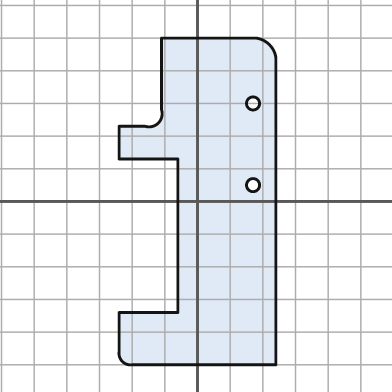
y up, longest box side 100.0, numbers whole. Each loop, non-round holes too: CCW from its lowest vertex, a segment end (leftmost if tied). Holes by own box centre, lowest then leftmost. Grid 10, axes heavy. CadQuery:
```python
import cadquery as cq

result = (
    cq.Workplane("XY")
    .moveTo(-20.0, -50.0)
    .lineTo(24.0, -50.0)
    .lineTo(24.0, 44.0)
    .threePointArc((22.0, 48.0), (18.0, 50.0))
    .lineTo(-11.0, 50.0)
    .lineTo(-11.0, 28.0)
    .threePointArc((-12.0, 24.0), (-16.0, 23.0))
    .lineTo(-24.0, 23.0)
    .lineTo(-24.0, 13.0)
    .lineTo(-6.0, 13.0)
    .lineTo(-6.0, -34.0)
    .lineTo(-24.0, -34.0)
    .lineTo(-24.0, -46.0)
    .threePointArc((-23.0, -49.0), (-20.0, -50.0))
    .close()
    .moveTo(17.0, 5.0)
    .circle(2.0)
    .moveTo(17.0, 30.0)
    .circle(2.0)
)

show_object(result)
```